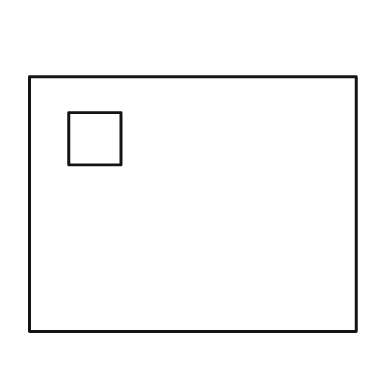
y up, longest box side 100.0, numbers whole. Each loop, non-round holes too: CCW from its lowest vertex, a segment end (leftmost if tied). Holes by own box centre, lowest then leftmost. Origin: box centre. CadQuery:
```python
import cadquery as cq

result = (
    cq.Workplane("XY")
    .moveTo(-50.0, -39.0)
    .lineTo(50.0, -39.0)
    .lineTo(50.0, 39.0)
    .lineTo(-50.0, 39.0)
    .close()
    .moveTo(-38.0, 12.0)
    .lineTo(-22.0, 12.0)
    .lineTo(-22.0, 28.0)
    .lineTo(-38.0, 28.0)
    .close()
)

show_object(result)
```